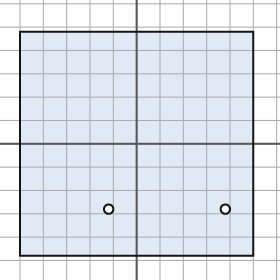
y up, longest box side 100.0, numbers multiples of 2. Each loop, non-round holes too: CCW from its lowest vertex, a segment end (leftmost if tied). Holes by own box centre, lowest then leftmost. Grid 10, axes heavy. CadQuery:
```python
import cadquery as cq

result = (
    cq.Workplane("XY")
    .moveTo(-50.0, -48.0)
    .lineTo(50.0, -48.0)
    .lineTo(50.0, 48.0)
    .lineTo(-50.0, 48.0)
    .close()
    .moveTo(-12.0, -28.0)
    .circle(2.0)
    .moveTo(38.0, -28.0)
    .circle(2.0)
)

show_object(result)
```